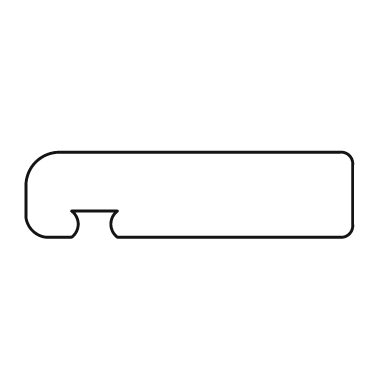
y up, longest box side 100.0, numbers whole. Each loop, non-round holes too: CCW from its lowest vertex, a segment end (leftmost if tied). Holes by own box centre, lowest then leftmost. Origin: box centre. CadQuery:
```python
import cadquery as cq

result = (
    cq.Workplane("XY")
    .moveTo(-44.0, -13.0)
    .lineTo(-36.0, -13.0)
    .threePointArc((-34.0, -9.0), (-36.0, -5.0))
    .lineTo(-22.0, -5.0)
    .threePointArc((-24.0, -9.0), (-22.0, -13.0))
    .lineTo(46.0, -13.0)
    .threePointArc((49.0, -12.0), (50.0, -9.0))
    .lineTo(50.0, 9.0)
    .threePointArc((49.0, 12.0), (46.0, 13.0))
    .lineTo(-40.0, 13.0)
    .threePointArc((-47.0, 10.0), (-50.0, 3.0))
    .lineTo(-50.0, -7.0)
    .threePointArc((-48.0, -11.0), (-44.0, -13.0))
    .close()
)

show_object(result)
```